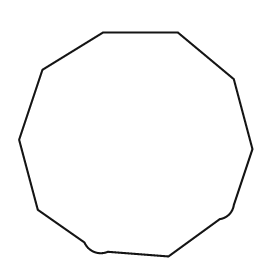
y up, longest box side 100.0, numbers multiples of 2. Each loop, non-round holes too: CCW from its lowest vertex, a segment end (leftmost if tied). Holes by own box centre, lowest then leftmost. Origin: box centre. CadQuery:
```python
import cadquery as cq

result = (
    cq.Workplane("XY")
    .moveTo(14.0, -48.0)
    .lineTo(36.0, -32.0)
    .threePointArc((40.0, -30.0), (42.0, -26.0))
    .lineTo(50.0, -2.0)
    .lineTo(42.0, 28.0)
    .lineTo(18.0, 48.0)
    .lineTo(-14.0, 48.0)
    .lineTo(-40.0, 32.0)
    .lineTo(-50.0, 2.0)
    .lineTo(-42.0, -28.0)
    .lineTo(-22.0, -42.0)
    .threePointArc((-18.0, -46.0), (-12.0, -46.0))
    .close()
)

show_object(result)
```